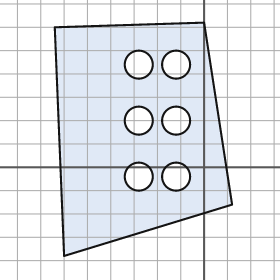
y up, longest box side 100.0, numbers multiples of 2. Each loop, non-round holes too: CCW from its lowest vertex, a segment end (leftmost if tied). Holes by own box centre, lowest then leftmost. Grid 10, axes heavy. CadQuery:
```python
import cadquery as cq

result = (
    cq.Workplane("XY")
    .moveTo(-60.0, -38.0)
    .lineTo(12.0, -16.0)
    .lineTo(0.0, 62.0)
    .lineTo(-64.0, 60.0)
    .close()
    .moveTo(-28.0, -4.0)
    .circle(6.0)
    .moveTo(-12.0, -4.0)
    .circle(6.0)
    .moveTo(-28.0, 20.0)
    .circle(6.0)
    .moveTo(-12.0, 20.0)
    .circle(6.0)
    .moveTo(-28.0, 44.0)
    .circle(6.0)
    .moveTo(-12.0, 44.0)
    .circle(6.0)
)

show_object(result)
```